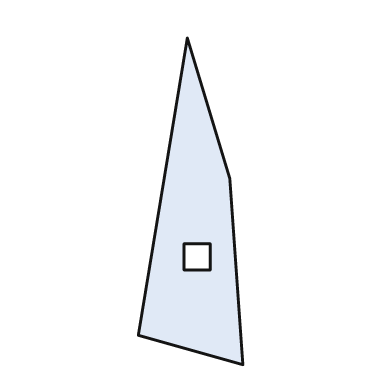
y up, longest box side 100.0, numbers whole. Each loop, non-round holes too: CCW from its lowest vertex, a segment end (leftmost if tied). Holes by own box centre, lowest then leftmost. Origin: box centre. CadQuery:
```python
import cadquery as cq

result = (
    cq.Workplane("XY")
    .moveTo(16.0, -50.0)
    .lineTo(12.0, 7.0)
    .lineTo(-1.0, 50.0)
    .lineTo(-16.0, -41.0)
    .close()
    .moveTo(-2.0, -21.0)
    .lineTo(6.0, -21.0)
    .lineTo(6.0, -13.0)
    .lineTo(-2.0, -13.0)
    .close()
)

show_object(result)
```